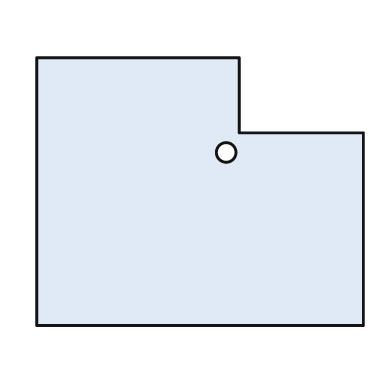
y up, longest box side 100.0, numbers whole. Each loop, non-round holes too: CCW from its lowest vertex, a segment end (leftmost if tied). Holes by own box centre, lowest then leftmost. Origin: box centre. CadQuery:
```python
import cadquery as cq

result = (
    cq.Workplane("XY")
    .moveTo(-50.0, -41.0)
    .lineTo(50.0, -41.0)
    .lineTo(50.0, 18.0)
    .lineTo(12.0, 18.0)
    .lineTo(12.0, 41.0)
    .lineTo(-50.0, 41.0)
    .close()
    .moveTo(8.0, 12.0)
    .circle(3.0)
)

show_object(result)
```